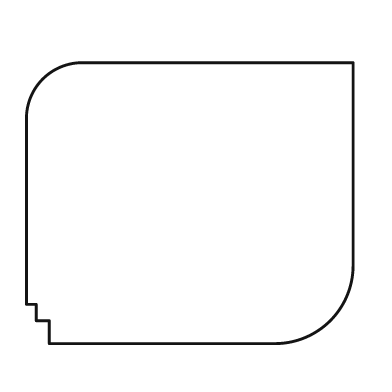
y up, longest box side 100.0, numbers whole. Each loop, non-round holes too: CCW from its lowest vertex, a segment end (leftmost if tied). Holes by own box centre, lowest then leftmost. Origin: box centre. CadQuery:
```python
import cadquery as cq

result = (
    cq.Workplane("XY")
    .moveTo(-43.0, -43.0)
    .lineTo(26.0, -43.0)
    .threePointArc((43.0, -36.0), (50.0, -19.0))
    .lineTo(50.0, 43.0)
    .lineTo(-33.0, 43.0)
    .threePointArc((-45.0, 38.0), (-50.0, 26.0))
    .lineTo(-50.0, -31.0)
    .lineTo(-47.0, -31.0)
    .lineTo(-47.0, -36.0)
    .lineTo(-43.0, -36.0)
    .close()
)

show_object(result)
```